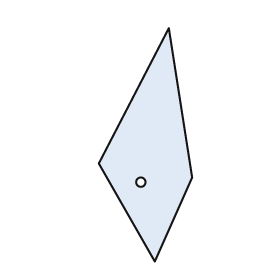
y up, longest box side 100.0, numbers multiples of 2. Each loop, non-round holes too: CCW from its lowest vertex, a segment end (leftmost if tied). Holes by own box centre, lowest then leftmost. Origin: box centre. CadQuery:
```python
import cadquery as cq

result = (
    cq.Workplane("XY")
    .moveTo(4.0, -50.0)
    .lineTo(20.0, -14.0)
    .lineTo(10.0, 50.0)
    .lineTo(-20.0, -8.0)
    .close()
    .moveTo(-2.0, -16.0)
    .circle(2.0)
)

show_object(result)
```